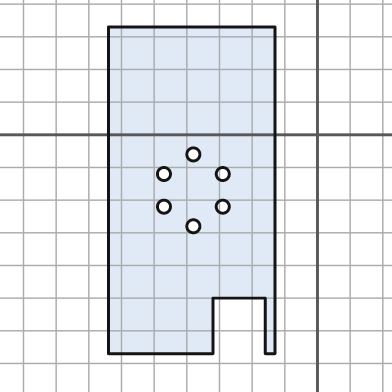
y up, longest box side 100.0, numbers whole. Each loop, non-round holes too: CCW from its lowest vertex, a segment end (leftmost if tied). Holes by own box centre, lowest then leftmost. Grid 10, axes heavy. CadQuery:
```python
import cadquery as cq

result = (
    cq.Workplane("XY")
    .moveTo(-64.0, -67.0)
    .lineTo(-32.0, -67.0)
    .lineTo(-32.0, -50.0)
    .lineTo(-16.0, -50.0)
    .lineTo(-16.0, -67.0)
    .lineTo(-13.0, -67.0)
    .lineTo(-13.0, 33.0)
    .lineTo(-64.0, 33.0)
    .close()
    .moveTo(-38.0, -28.0)
    .circle(2.0)
    .moveTo(-47.0, -22.0)
    .circle(2.0)
    .moveTo(-29.0, -22.0)
    .circle(2.0)
    .moveTo(-47.0, -12.0)
    .circle(2.0)
    .moveTo(-29.0, -12.0)
    .circle(2.0)
    .moveTo(-38.0, -6.0)
    .circle(2.0)
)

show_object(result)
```